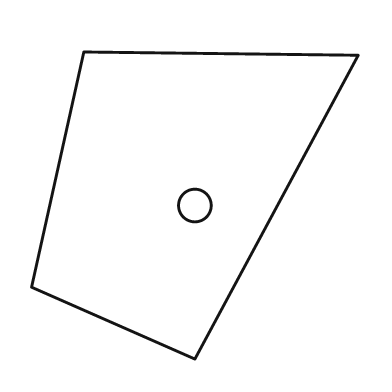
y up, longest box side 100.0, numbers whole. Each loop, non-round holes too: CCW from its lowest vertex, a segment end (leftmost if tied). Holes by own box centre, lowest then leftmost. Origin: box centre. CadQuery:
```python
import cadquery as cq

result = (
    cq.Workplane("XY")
    .moveTo(0.0, -47.0)
    .lineTo(50.0, 46.0)
    .lineTo(-34.0, 47.0)
    .lineTo(-50.0, -25.0)
    .close()
    .moveTo(0.0, 0.0)
    .circle(5.0)
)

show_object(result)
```